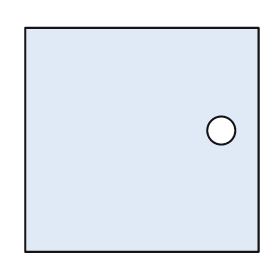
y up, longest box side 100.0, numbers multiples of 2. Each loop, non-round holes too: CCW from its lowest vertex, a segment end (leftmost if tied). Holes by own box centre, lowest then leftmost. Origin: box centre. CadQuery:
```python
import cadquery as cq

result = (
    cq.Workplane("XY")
    .moveTo(-50.0, -48.0)
    .lineTo(50.0, -48.0)
    .lineTo(50.0, 48.0)
    .lineTo(-50.0, 48.0)
    .close()
    .moveTo(34.0, 4.0)
    .circle(6.0)
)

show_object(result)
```